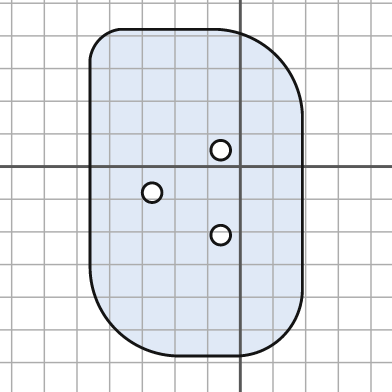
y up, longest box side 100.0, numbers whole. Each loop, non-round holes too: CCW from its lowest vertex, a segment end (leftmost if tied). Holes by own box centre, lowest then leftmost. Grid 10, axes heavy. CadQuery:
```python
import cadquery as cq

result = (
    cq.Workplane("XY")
    .moveTo(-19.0, -58.0)
    .lineTo(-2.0, -58.0)
    .threePointArc((13.0, -52.0), (19.0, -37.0))
    .lineTo(19.0, 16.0)
    .threePointArc((11.0, 34.0), (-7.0, 42.0))
    .lineTo(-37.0, 42.0)
    .threePointArc((-43.0, 39.0), (-46.0, 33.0))
    .lineTo(-46.0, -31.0)
    .threePointArc((-38.0, -50.0), (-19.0, -58.0))
    .close()
    .moveTo(-6.0, -21.0)
    .circle(3.0)
    .moveTo(-27.0, -8.0)
    .circle(3.0)
    .moveTo(-6.0, 5.0)
    .circle(3.0)
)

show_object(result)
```